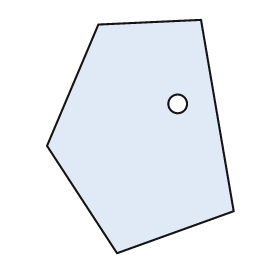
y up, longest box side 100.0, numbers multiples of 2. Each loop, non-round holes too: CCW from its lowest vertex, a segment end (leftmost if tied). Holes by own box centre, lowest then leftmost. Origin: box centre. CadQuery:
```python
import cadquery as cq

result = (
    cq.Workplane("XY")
    .moveTo(-10.0, -50.0)
    .lineTo(40.0, -32.0)
    .lineTo(26.0, 50.0)
    .lineTo(-18.0, 48.0)
    .lineTo(-40.0, -4.0)
    .close()
    .moveTo(16.0, 14.0)
    .circle(4.0)
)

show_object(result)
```